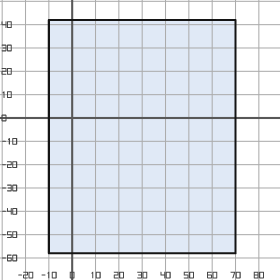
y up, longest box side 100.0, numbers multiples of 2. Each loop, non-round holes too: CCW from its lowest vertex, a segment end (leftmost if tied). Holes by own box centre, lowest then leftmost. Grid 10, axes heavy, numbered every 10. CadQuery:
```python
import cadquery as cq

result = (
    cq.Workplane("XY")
    .moveTo(-10.0, -58.0)
    .lineTo(70.0, -58.0)
    .lineTo(70.0, 42.0)
    .lineTo(-10.0, 42.0)
    .close()
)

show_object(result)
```